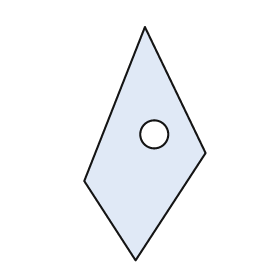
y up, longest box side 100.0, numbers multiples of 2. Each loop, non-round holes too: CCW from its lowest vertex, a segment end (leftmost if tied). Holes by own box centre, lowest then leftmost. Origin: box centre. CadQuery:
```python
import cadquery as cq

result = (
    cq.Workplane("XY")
    .moveTo(-4.0, -50.0)
    .lineTo(26.0, -4.0)
    .lineTo(0.0, 50.0)
    .lineTo(-26.0, -16.0)
    .close()
    .moveTo(4.0, 4.0)
    .circle(6.0)
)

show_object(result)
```